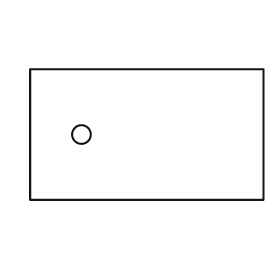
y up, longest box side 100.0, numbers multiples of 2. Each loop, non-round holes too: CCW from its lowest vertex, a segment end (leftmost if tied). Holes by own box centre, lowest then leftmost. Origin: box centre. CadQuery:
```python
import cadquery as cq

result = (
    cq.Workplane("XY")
    .moveTo(-50.0, -28.0)
    .lineTo(50.0, -28.0)
    .lineTo(50.0, 28.0)
    .lineTo(-50.0, 28.0)
    .close()
    .moveTo(-28.0, 0.0)
    .circle(4.0)
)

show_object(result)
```